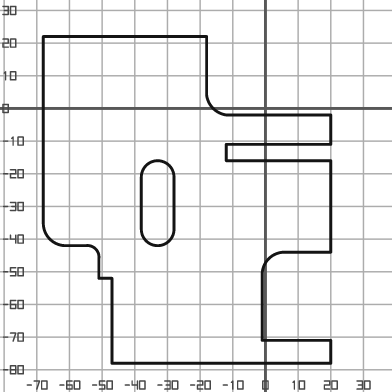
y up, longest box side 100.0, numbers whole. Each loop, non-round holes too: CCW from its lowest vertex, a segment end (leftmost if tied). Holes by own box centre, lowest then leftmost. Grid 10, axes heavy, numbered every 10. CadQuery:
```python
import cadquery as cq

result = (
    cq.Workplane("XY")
    .moveTo(-47.0, -78.0)
    .lineTo(20.0, -78.0)
    .lineTo(20.0, -71.0)
    .lineTo(-1.0, -71.0)
    .lineTo(-1.0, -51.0)
    .threePointArc((1.0, -46.0), (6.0, -44.0))
    .lineTo(20.0, -44.0)
    .lineTo(20.0, -16.0)
    .lineTo(-12.0, -16.0)
    .lineTo(-12.0, -11.0)
    .lineTo(20.0, -11.0)
    .lineTo(20.0, -2.0)
    .lineTo(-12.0, -2.0)
    .threePointArc((-16.0, 0.0), (-18.0, 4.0))
    .lineTo(-18.0, 22.0)
    .lineTo(-68.0, 22.0)
    .lineTo(-68.0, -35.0)
    .threePointArc((-66.0, -40.0), (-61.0, -42.0))
    .lineTo(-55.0, -42.0)
    .threePointArc((-52.0, -43.0), (-51.0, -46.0))
    .lineTo(-51.0, -52.0)
    .lineTo(-47.0, -52.0)
    .close()
    .moveTo(-38.0, -37.0)
    .threePointArc((-33.0, -42.0), (-28.0, -37.0))
    .lineTo(-28.0, -21.0)
    .threePointArc((-33.0, -16.0), (-38.0, -21.0))
    .close()
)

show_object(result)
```